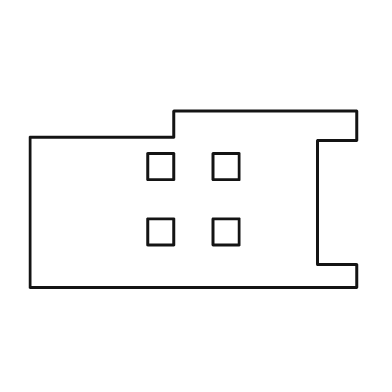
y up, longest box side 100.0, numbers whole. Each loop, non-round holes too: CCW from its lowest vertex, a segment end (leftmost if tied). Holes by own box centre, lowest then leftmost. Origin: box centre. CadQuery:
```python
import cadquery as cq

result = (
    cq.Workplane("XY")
    .moveTo(-50.0, -27.0)
    .lineTo(50.0, -27.0)
    .lineTo(50.0, -20.0)
    .lineTo(38.0, -20.0)
    .lineTo(38.0, 18.0)
    .lineTo(50.0, 18.0)
    .lineTo(50.0, 27.0)
    .lineTo(-6.0, 27.0)
    .lineTo(-6.0, 19.0)
    .lineTo(-50.0, 19.0)
    .close()
    .moveTo(-14.0, -14.0)
    .lineTo(-6.0, -14.0)
    .lineTo(-6.0, -6.0)
    .lineTo(-14.0, -6.0)
    .close()
    .moveTo(6.0, -14.0)
    .lineTo(14.0, -14.0)
    .lineTo(14.0, -6.0)
    .lineTo(6.0, -6.0)
    .close()
    .moveTo(-14.0, 6.0)
    .lineTo(-6.0, 6.0)
    .lineTo(-6.0, 14.0)
    .lineTo(-14.0, 14.0)
    .close()
    .moveTo(6.0, 6.0)
    .lineTo(14.0, 6.0)
    .lineTo(14.0, 14.0)
    .lineTo(6.0, 14.0)
    .close()
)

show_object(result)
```